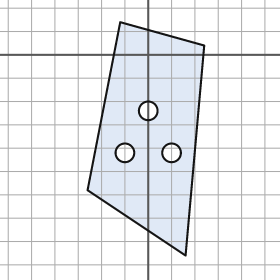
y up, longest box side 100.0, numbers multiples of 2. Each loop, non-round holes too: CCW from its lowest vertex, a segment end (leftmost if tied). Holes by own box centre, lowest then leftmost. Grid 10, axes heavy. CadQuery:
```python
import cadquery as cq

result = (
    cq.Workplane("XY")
    .moveTo(16.0, -86.0)
    .lineTo(24.0, 4.0)
    .lineTo(-12.0, 14.0)
    .lineTo(-26.0, -58.0)
    .close()
    .moveTo(-10.0, -42.0)
    .circle(4.0)
    .moveTo(10.0, -42.0)
    .circle(4.0)
    .moveTo(0.0, -24.0)
    .circle(4.0)
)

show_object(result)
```